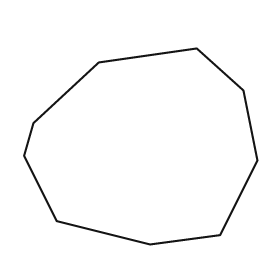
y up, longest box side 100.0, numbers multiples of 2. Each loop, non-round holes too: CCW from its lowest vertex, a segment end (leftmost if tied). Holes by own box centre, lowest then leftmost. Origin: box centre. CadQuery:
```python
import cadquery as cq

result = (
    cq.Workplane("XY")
    .moveTo(4.0, -42.0)
    .lineTo(34.0, -38.0)
    .lineTo(50.0, -6.0)
    .lineTo(44.0, 24.0)
    .lineTo(24.0, 42.0)
    .lineTo(-18.0, 36.0)
    .lineTo(-46.0, 10.0)
    .lineTo(-50.0, -4.0)
    .lineTo(-36.0, -32.0)
    .close()
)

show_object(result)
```